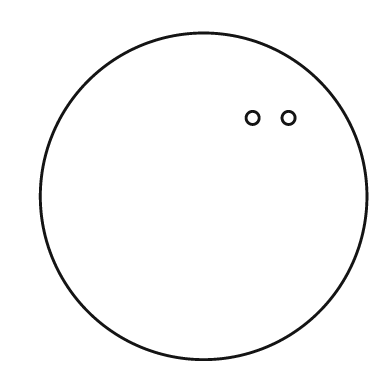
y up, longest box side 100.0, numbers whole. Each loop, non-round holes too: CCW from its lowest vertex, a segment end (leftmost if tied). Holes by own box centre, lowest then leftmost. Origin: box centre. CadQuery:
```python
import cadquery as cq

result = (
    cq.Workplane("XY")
    .moveTo(0.0, 0.0)
    .circle(50.0)
    .moveTo(15.0, 24.0)
    .circle(2.0)
    .moveTo(26.0, 24.0)
    .circle(2.0)
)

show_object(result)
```